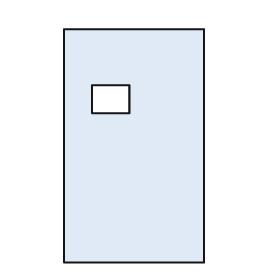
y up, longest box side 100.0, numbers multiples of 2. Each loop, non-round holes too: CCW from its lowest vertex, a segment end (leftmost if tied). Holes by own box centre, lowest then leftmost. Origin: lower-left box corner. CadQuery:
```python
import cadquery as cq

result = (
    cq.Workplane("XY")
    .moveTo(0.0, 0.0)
    .lineTo(60.0, 0.0)
    .lineTo(60.0, 100.0)
    .lineTo(0.0, 100.0)
    .close()
    .moveTo(12.0, 64.0)
    .lineTo(28.0, 64.0)
    .lineTo(28.0, 76.0)
    .lineTo(12.0, 76.0)
    .close()
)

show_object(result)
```